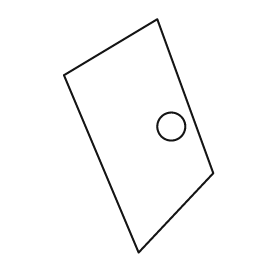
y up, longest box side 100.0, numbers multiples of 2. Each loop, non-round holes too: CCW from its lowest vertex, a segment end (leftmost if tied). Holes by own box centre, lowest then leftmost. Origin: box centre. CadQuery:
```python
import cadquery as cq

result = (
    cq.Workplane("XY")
    .moveTo(0.0, -50.0)
    .lineTo(32.0, -16.0)
    .lineTo(8.0, 50.0)
    .lineTo(-32.0, 26.0)
    .close()
    .moveTo(14.0, 4.0)
    .circle(6.0)
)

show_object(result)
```